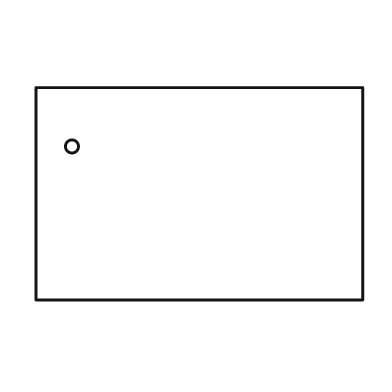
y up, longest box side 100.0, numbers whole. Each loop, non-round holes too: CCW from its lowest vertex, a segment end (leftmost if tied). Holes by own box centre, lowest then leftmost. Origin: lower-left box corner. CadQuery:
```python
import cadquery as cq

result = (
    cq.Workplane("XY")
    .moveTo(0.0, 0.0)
    .lineTo(100.0, 0.0)
    .lineTo(100.0, 65.0)
    .lineTo(0.0, 65.0)
    .close()
    .moveTo(11.0, 47.0)
    .circle(2.0)
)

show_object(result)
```